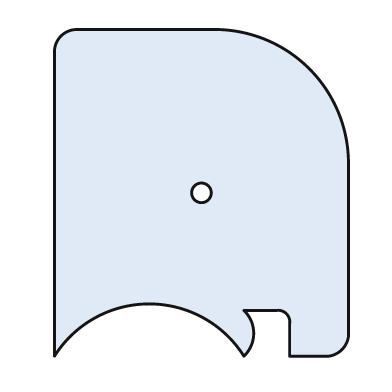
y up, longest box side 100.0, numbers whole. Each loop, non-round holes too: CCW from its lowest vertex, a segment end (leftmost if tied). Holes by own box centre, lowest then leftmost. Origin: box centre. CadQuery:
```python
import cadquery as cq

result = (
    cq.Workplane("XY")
    .moveTo(-45.0, -50.0)
    .threePointArc((-16.0, -34.0), (13.0, -50.0))
    .threePointArc((16.0, -43.0), (13.0, -36.0))
    .lineTo(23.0, -36.0)
    .threePointArc((26.0, -37.0), (27.0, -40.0))
    .lineTo(27.0, -50.0)
    .lineTo(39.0, -50.0)
    .threePointArc((43.0, -48.0), (45.0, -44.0))
    .lineTo(45.0, 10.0)
    .threePointArc((33.0, 38.0), (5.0, 50.0))
    .lineTo(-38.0, 50.0)
    .threePointArc((-43.0, 48.0), (-45.0, 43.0))
    .close()
    .moveTo(0.0, 0.0)
    .circle(3.0)
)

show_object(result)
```